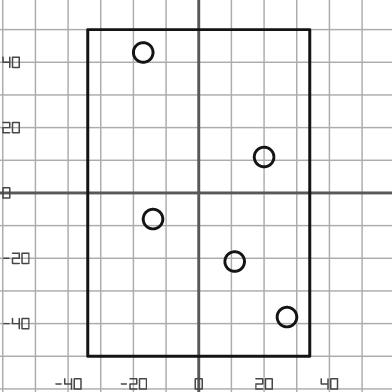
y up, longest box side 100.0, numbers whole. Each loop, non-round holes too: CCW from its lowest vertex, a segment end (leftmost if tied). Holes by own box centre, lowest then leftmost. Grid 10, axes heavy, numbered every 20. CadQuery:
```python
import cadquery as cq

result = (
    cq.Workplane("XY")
    .moveTo(-34.0, -50.0)
    .lineTo(34.0, -50.0)
    .lineTo(34.0, 50.0)
    .lineTo(-34.0, 50.0)
    .close()
    .moveTo(27.0, -38.0)
    .circle(3.0)
    .moveTo(11.0, -21.0)
    .circle(3.0)
    .moveTo(-14.0, -8.0)
    .circle(3.0)
    .moveTo(20.0, 11.0)
    .circle(3.0)
    .moveTo(-17.0, 43.0)
    .circle(3.0)
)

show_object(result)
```